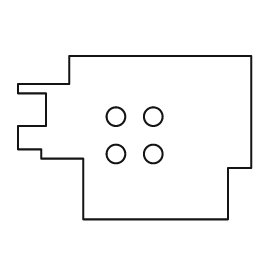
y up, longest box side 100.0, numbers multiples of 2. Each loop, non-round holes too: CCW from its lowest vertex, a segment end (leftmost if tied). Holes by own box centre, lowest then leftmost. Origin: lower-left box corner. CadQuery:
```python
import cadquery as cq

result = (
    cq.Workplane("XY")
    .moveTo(28.0, 0.0)
    .lineTo(90.0, 0.0)
    .lineTo(90.0, 22.0)
    .lineTo(100.0, 22.0)
    .lineTo(100.0, 70.0)
    .lineTo(22.0, 70.0)
    .lineTo(22.0, 58.0)
    .lineTo(0.0, 58.0)
    .lineTo(0.0, 54.0)
    .lineTo(12.0, 54.0)
    .lineTo(12.0, 40.0)
    .lineTo(0.0, 40.0)
    .lineTo(0.0, 30.0)
    .lineTo(10.0, 30.0)
    .lineTo(10.0, 26.0)
    .lineTo(28.0, 26.0)
    .close()
    .moveTo(42.0, 28.0)
    .circle(4.0)
    .moveTo(58.0, 28.0)
    .circle(4.0)
    .moveTo(42.0, 44.0)
    .circle(4.0)
    .moveTo(58.0, 44.0)
    .circle(4.0)
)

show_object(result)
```